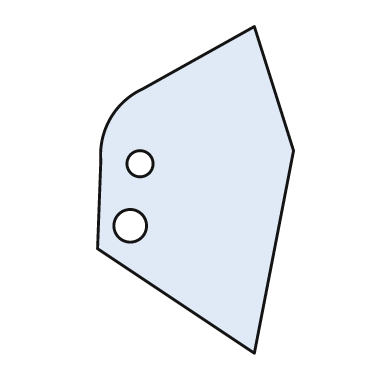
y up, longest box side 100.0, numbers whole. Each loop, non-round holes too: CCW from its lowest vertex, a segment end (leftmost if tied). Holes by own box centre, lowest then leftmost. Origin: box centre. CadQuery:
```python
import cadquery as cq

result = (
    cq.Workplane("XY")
    .moveTo(18.0, -50.0)
    .lineTo(30.0, 12.0)
    .lineTo(18.0, 50.0)
    .lineTo(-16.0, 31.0)
    .threePointArc((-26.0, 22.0), (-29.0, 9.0))
    .lineTo(-30.0, -18.0)
    .close()
    .moveTo(-20.0, -11.0)
    .circle(5.0)
    .moveTo(-17.0, 8.0)
    .circle(4.0)
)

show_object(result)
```